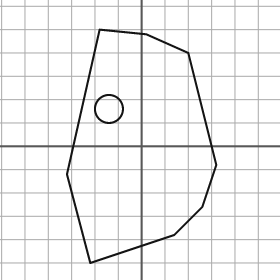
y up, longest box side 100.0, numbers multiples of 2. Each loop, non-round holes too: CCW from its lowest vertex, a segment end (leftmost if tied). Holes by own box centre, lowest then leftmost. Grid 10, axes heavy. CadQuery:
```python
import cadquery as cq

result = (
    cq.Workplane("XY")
    .moveTo(-22.0, -50.0)
    .lineTo(14.0, -38.0)
    .lineTo(26.0, -26.0)
    .lineTo(32.0, -8.0)
    .lineTo(20.0, 40.0)
    .lineTo(2.0, 48.0)
    .lineTo(-18.0, 50.0)
    .lineTo(-32.0, -12.0)
    .close()
    .moveTo(-14.0, 16.0)
    .circle(6.0)
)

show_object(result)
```